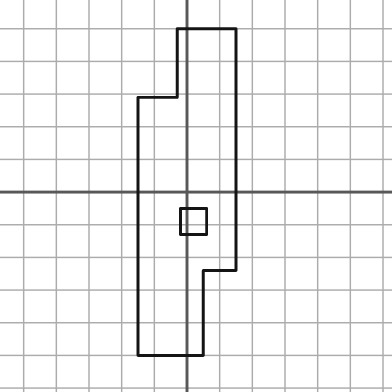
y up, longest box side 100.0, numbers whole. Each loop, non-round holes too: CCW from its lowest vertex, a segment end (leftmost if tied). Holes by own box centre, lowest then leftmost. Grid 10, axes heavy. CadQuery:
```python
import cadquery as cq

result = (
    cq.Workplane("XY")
    .moveTo(-15.0, -50.0)
    .lineTo(5.0, -50.0)
    .lineTo(5.0, -24.0)
    .lineTo(15.0, -24.0)
    .lineTo(15.0, 50.0)
    .lineTo(-3.0, 50.0)
    .lineTo(-3.0, 29.0)
    .lineTo(-15.0, 29.0)
    .close()
    .moveTo(-2.0, -13.0)
    .lineTo(6.0, -13.0)
    .lineTo(6.0, -5.0)
    .lineTo(-2.0, -5.0)
    .close()
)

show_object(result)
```